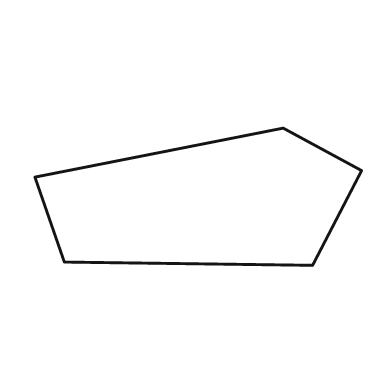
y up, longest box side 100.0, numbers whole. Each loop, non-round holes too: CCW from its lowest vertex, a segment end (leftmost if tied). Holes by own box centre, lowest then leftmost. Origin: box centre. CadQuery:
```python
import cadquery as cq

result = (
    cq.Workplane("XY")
    .moveTo(35.0, -21.0)
    .lineTo(50.0, 8.0)
    .lineTo(26.0, 21.0)
    .lineTo(-50.0, 6.0)
    .lineTo(-41.0, -20.0)
    .close()
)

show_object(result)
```